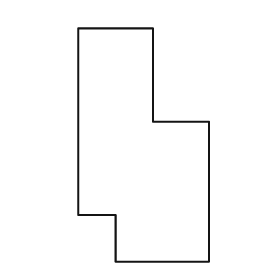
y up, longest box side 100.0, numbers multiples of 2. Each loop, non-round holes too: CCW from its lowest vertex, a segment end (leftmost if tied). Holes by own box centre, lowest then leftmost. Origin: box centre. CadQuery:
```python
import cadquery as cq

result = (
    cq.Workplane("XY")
    .moveTo(-12.0, -50.0)
    .lineTo(28.0, -50.0)
    .lineTo(28.0, 10.0)
    .lineTo(4.0, 10.0)
    .lineTo(4.0, 50.0)
    .lineTo(-28.0, 50.0)
    .lineTo(-28.0, -30.0)
    .lineTo(-12.0, -30.0)
    .close()
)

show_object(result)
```